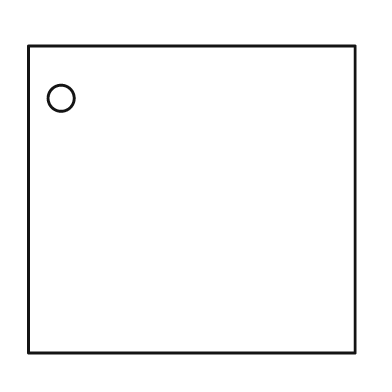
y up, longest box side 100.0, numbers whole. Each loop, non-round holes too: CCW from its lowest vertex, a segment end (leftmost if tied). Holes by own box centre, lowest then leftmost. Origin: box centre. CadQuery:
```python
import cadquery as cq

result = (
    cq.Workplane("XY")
    .moveTo(-50.0, -47.0)
    .lineTo(50.0, -47.0)
    .lineTo(50.0, 47.0)
    .lineTo(-50.0, 47.0)
    .close()
    .moveTo(-40.0, 31.0)
    .circle(4.0)
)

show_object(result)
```